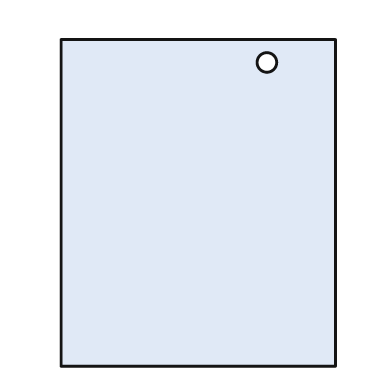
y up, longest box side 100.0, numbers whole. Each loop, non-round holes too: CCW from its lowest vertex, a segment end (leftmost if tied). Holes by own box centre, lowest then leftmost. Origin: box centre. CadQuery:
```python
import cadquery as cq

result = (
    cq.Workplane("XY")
    .moveTo(-42.0, -50.0)
    .lineTo(42.0, -50.0)
    .lineTo(42.0, 50.0)
    .lineTo(-42.0, 50.0)
    .close()
    .moveTo(21.0, 43.0)
    .circle(3.0)
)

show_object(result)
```